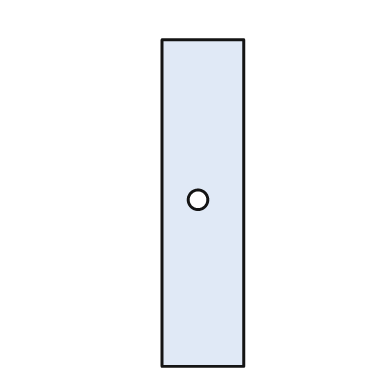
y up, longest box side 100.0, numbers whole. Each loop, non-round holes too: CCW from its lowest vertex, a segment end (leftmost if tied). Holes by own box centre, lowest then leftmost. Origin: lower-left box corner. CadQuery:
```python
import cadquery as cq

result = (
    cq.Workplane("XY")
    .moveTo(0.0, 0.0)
    .lineTo(25.0, 0.0)
    .lineTo(25.0, 100.0)
    .lineTo(0.0, 100.0)
    .close()
    .moveTo(11.0, 51.0)
    .circle(3.0)
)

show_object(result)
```